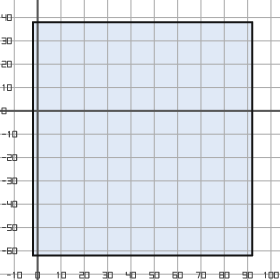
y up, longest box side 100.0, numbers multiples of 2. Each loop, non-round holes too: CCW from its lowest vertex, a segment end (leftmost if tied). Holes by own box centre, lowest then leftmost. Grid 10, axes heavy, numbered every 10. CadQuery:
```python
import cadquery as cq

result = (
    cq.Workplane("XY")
    .moveTo(-2.0, -62.0)
    .lineTo(92.0, -62.0)
    .lineTo(92.0, 38.0)
    .lineTo(-2.0, 38.0)
    .close()
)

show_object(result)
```